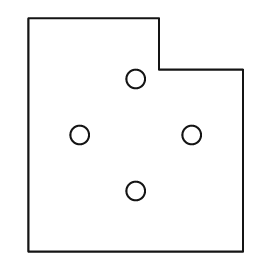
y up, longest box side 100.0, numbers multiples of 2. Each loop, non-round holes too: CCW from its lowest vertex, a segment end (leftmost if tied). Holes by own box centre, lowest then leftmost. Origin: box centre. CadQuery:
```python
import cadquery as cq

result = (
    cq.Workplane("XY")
    .moveTo(-46.0, -50.0)
    .lineTo(46.0, -50.0)
    .lineTo(46.0, 28.0)
    .lineTo(10.0, 28.0)
    .lineTo(10.0, 50.0)
    .lineTo(-46.0, 50.0)
    .close()
    .moveTo(0.0, -24.0)
    .circle(4.0)
    .moveTo(-24.0, 0.0)
    .circle(4.0)
    .moveTo(24.0, 0.0)
    .circle(4.0)
    .moveTo(0.0, 24.0)
    .circle(4.0)
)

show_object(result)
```